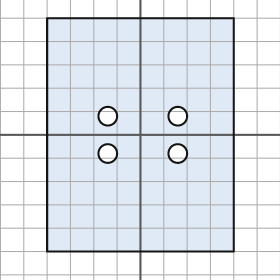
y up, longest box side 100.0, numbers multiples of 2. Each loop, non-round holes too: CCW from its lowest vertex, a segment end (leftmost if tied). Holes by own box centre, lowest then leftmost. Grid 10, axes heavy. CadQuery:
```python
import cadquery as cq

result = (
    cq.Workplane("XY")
    .moveTo(-40.0, -50.0)
    .lineTo(40.0, -50.0)
    .lineTo(40.0, 50.0)
    .lineTo(-40.0, 50.0)
    .close()
    .moveTo(-14.0, -8.0)
    .circle(4.0)
    .moveTo(16.0, -8.0)
    .circle(4.0)
    .moveTo(-14.0, 8.0)
    .circle(4.0)
    .moveTo(16.0, 8.0)
    .circle(4.0)
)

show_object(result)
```